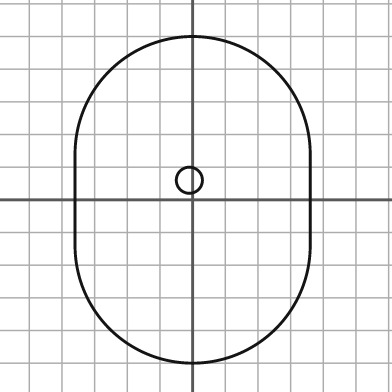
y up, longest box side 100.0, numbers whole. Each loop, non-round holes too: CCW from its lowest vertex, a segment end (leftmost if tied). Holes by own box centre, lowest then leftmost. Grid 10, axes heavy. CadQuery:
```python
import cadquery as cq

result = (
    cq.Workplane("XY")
    .moveTo(-36.0, -14.0)
    .threePointArc((0.0, -50.0), (36.0, -14.0))
    .lineTo(36.0, 14.0)
    .threePointArc((0.0, 50.0), (-36.0, 14.0))
    .close()
    .moveTo(-1.0, 6.0)
    .circle(4.0)
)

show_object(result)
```